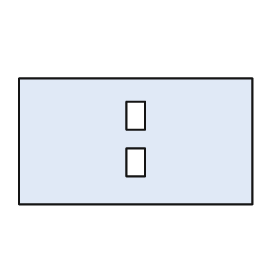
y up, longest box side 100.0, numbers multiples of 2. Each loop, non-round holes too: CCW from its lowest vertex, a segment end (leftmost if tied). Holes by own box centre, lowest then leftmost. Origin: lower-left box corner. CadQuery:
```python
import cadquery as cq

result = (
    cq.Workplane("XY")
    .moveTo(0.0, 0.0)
    .lineTo(100.0, 0.0)
    .lineTo(100.0, 54.0)
    .lineTo(0.0, 54.0)
    .close()
    .moveTo(46.0, 12.0)
    .lineTo(54.0, 12.0)
    .lineTo(54.0, 24.0)
    .lineTo(46.0, 24.0)
    .close()
    .moveTo(46.0, 32.0)
    .lineTo(54.0, 32.0)
    .lineTo(54.0, 44.0)
    .lineTo(46.0, 44.0)
    .close()
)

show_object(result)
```